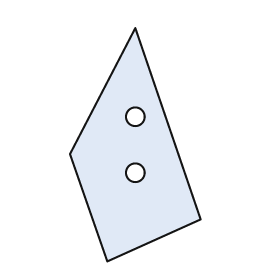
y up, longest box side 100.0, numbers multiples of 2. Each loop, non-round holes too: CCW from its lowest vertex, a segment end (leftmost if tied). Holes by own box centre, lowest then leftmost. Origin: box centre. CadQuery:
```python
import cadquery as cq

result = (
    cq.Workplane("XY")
    .moveTo(-12.0, -50.0)
    .lineTo(28.0, -32.0)
    .lineTo(0.0, 50.0)
    .lineTo(-28.0, -4.0)
    .close()
    .moveTo(0.0, -12.0)
    .circle(4.0)
    .moveTo(0.0, 12.0)
    .circle(4.0)
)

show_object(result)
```